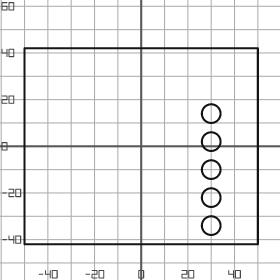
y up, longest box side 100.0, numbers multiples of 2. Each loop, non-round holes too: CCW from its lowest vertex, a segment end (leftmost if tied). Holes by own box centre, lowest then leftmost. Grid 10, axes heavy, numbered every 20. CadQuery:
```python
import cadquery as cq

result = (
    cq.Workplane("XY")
    .moveTo(-50.0, -42.0)
    .lineTo(50.0, -42.0)
    .lineTo(50.0, 42.0)
    .lineTo(-50.0, 42.0)
    .close()
    .moveTo(30.0, -34.0)
    .circle(4.0)
    .moveTo(30.0, -22.0)
    .circle(4.0)
    .moveTo(30.0, -10.0)
    .circle(4.0)
    .moveTo(30.0, 2.0)
    .circle(4.0)
    .moveTo(30.0, 14.0)
    .circle(4.0)
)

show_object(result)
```